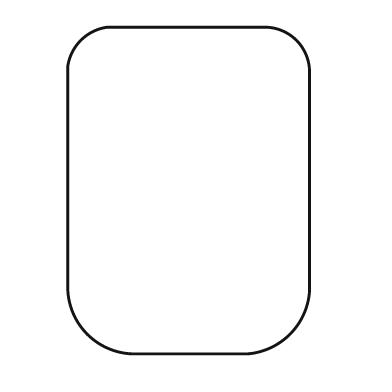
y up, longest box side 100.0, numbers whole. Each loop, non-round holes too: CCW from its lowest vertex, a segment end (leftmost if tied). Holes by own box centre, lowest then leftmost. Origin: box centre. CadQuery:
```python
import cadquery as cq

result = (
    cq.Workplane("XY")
    .moveTo(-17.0, -50.0)
    .lineTo(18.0, -50.0)
    .threePointArc((31.0, -44.0), (37.0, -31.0))
    .lineTo(37.0, 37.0)
    .threePointArc((33.0, 46.0), (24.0, 50.0))
    .lineTo(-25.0, 50.0)
    .threePointArc((-33.0, 46.0), (-37.0, 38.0))
    .lineTo(-37.0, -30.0)
    .threePointArc((-31.0, -44.0), (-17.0, -50.0))
    .close()
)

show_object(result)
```